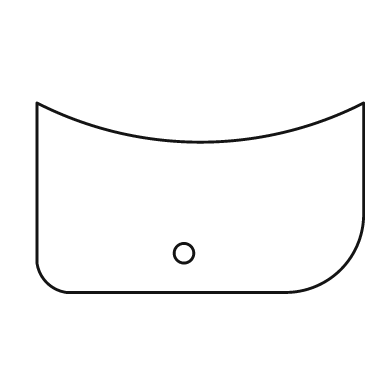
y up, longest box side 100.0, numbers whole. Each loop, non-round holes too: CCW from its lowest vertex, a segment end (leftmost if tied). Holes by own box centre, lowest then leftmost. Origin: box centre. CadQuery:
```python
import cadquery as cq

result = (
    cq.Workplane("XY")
    .moveTo(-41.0, -29.0)
    .lineTo(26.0, -29.0)
    .threePointArc((43.0, -22.0), (50.0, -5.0))
    .lineTo(50.0, 29.0)
    .threePointArc((0.0, 17.0), (-50.0, 29.0))
    .lineTo(-50.0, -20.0)
    .threePointArc((-47.0, -26.0), (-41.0, -29.0))
    .close()
    .moveTo(-5.0, -17.0)
    .circle(3.0)
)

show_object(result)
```